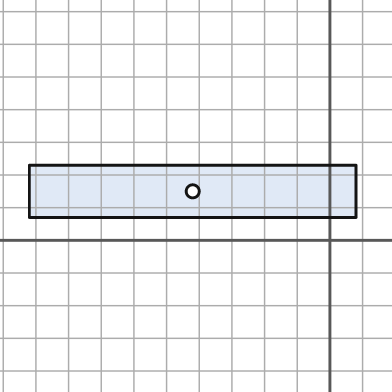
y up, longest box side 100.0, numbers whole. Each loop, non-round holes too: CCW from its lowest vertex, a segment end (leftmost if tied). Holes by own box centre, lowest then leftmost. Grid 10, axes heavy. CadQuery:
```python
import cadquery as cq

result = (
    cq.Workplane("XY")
    .moveTo(-92.0, 7.0)
    .lineTo(8.0, 7.0)
    .lineTo(8.0, 23.0)
    .lineTo(-92.0, 23.0)
    .close()
    .moveTo(-42.0, 15.0)
    .circle(2.0)
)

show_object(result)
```